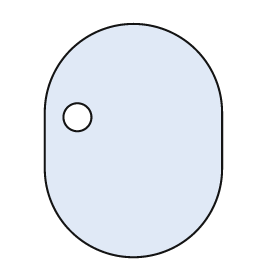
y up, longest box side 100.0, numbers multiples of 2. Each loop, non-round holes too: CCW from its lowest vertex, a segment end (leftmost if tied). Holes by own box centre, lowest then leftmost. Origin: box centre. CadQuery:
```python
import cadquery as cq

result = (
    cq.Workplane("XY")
    .moveTo(-38.0, -12.0)
    .threePointArc((0.0, -50.0), (38.0, -12.0))
    .lineTo(38.0, 12.0)
    .threePointArc((0.0, 50.0), (-38.0, 12.0))
    .close()
    .moveTo(-24.0, 10.0)
    .circle(6.0)
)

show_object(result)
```